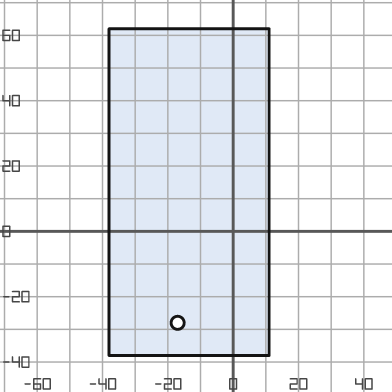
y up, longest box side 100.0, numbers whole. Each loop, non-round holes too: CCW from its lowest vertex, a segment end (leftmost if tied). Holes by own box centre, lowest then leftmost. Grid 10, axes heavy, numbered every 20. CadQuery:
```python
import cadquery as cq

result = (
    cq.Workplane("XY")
    .moveTo(-38.0, -38.0)
    .lineTo(11.0, -38.0)
    .lineTo(11.0, 62.0)
    .lineTo(-38.0, 62.0)
    .close()
    .moveTo(-17.0, -28.0)
    .circle(2.0)
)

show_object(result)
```